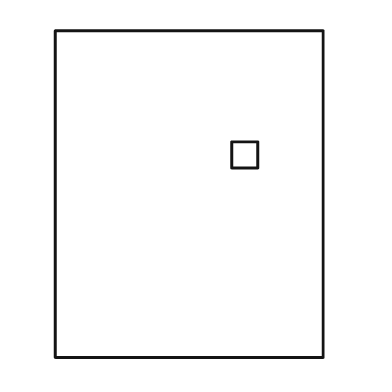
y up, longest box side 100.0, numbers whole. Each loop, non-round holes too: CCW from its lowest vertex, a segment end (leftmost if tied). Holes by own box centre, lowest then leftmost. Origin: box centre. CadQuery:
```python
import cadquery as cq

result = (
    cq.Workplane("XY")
    .moveTo(-41.0, -50.0)
    .lineTo(41.0, -50.0)
    .lineTo(41.0, 50.0)
    .lineTo(-41.0, 50.0)
    .close()
    .moveTo(13.0, 8.0)
    .lineTo(21.0, 8.0)
    .lineTo(21.0, 16.0)
    .lineTo(13.0, 16.0)
    .close()
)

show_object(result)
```